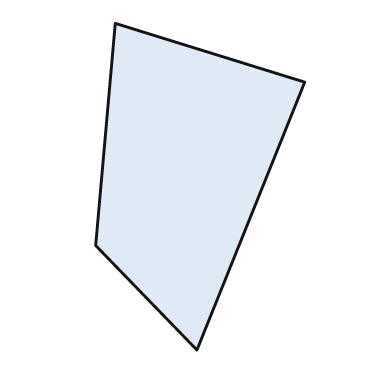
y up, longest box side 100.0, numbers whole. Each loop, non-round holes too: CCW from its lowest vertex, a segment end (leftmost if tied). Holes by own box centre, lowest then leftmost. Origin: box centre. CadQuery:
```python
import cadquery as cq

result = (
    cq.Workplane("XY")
    .moveTo(-1.0, -50.0)
    .lineTo(32.0, 32.0)
    .lineTo(-26.0, 50.0)
    .lineTo(-32.0, -18.0)
    .close()
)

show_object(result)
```